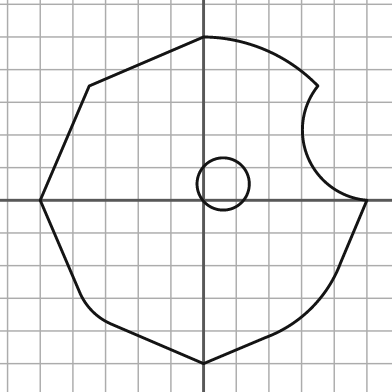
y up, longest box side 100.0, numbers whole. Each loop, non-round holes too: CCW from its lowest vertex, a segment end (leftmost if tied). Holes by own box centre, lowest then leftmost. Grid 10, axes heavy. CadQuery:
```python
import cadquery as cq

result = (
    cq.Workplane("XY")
    .moveTo(0.0, -50.0)
    .lineTo(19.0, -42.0)
    .threePointArc((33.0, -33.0), (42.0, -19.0))
    .lineTo(50.0, 0.0)
    .threePointArc((32.0, 13.0), (35.0, 35.0))
    .threePointArc((19.0, 46.0), (0.0, 50.0))
    .lineTo(-35.0, 35.0)
    .lineTo(-50.0, 0.0)
    .lineTo(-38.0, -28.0)
    .threePointArc((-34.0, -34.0), (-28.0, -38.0))
    .close()
    .moveTo(6.0, 5.0)
    .circle(8.0)
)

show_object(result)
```